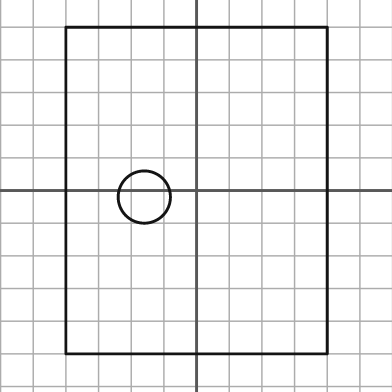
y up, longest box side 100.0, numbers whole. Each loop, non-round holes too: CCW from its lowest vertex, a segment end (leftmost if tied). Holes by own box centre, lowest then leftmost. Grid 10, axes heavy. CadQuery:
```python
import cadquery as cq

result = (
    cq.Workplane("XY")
    .moveTo(-40.0, -50.0)
    .lineTo(40.0, -50.0)
    .lineTo(40.0, 50.0)
    .lineTo(-40.0, 50.0)
    .close()
    .moveTo(-16.0, -2.0)
    .circle(8.0)
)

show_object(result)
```